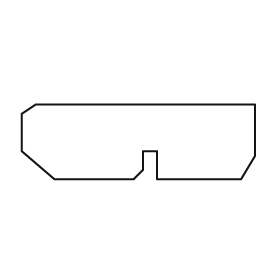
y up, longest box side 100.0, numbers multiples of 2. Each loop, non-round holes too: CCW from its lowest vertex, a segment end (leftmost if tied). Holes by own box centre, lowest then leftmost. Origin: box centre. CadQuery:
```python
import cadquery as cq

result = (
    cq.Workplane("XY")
    .moveTo(-36.0, -16.0)
    .lineTo(-2.0, -16.0)
    .lineTo(2.0, -12.0)
    .lineTo(2.0, -4.0)
    .lineTo(8.0, -4.0)
    .lineTo(8.0, -16.0)
    .lineTo(44.0, -16.0)
    .lineTo(50.0, -6.0)
    .lineTo(50.0, 16.0)
    .lineTo(-44.0, 16.0)
    .lineTo(-50.0, 12.0)
    .lineTo(-50.0, -4.0)
    .close()
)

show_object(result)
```